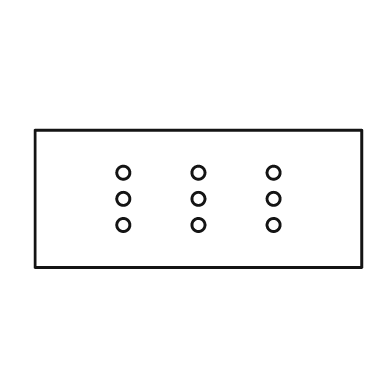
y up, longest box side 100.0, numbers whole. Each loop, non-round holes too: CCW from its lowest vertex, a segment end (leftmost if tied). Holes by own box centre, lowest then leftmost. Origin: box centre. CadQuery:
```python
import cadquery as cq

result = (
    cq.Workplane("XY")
    .moveTo(-50.0, -21.0)
    .lineTo(50.0, -21.0)
    .lineTo(50.0, 21.0)
    .lineTo(-50.0, 21.0)
    .close()
    .moveTo(-23.0, -8.0)
    .circle(2.0)
    .moveTo(0.0, -8.0)
    .circle(2.0)
    .moveTo(23.0, -8.0)
    .circle(2.0)
    .moveTo(-23.0, 0.0)
    .circle(2.0)
    .moveTo(0.0, 0.0)
    .circle(2.0)
    .moveTo(23.0, 0.0)
    .circle(2.0)
    .moveTo(-23.0, 8.0)
    .circle(2.0)
    .moveTo(0.0, 8.0)
    .circle(2.0)
    .moveTo(23.0, 8.0)
    .circle(2.0)
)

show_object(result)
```